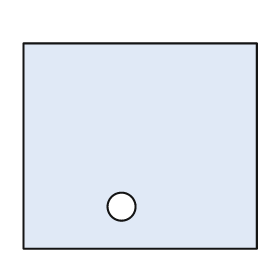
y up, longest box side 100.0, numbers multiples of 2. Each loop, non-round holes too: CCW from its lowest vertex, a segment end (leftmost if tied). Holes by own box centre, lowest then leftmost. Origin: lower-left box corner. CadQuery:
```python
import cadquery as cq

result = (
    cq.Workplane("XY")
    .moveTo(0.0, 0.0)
    .lineTo(100.0, 0.0)
    .lineTo(100.0, 88.0)
    .lineTo(0.0, 88.0)
    .close()
    .moveTo(42.0, 18.0)
    .circle(6.0)
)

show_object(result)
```